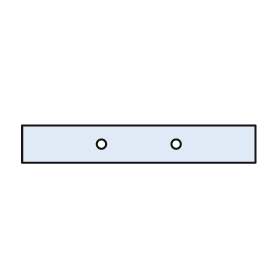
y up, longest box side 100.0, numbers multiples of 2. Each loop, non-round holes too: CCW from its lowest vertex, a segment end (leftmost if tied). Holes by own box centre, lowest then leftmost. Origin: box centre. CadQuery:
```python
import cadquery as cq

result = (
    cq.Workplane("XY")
    .moveTo(-50.0, -8.0)
    .lineTo(50.0, -8.0)
    .lineTo(50.0, 8.0)
    .lineTo(-50.0, 8.0)
    .close()
    .moveTo(-16.0, 0.0)
    .circle(2.0)
    .moveTo(16.0, 0.0)
    .circle(2.0)
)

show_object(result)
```